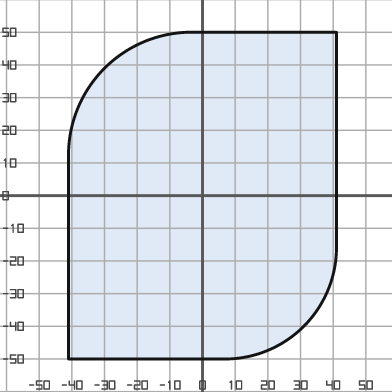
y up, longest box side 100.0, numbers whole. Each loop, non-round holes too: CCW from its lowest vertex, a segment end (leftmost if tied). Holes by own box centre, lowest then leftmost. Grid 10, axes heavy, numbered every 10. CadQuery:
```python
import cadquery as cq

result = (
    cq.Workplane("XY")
    .moveTo(-41.0, -50.0)
    .lineTo(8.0, -50.0)
    .threePointArc((31.0, -40.0), (41.0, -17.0))
    .lineTo(41.0, 50.0)
    .lineTo(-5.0, 50.0)
    .threePointArc((-30.0, 39.0), (-41.0, 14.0))
    .close()
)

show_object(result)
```